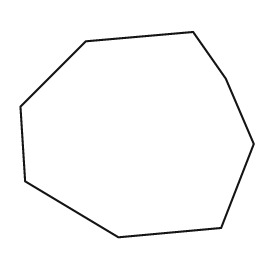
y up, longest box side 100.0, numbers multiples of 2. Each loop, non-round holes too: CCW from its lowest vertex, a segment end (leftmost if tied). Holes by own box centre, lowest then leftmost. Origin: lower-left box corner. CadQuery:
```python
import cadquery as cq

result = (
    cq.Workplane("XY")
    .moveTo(42.0, 0.0)
    .lineTo(86.0, 4.0)
    .lineTo(100.0, 40.0)
    .lineTo(88.0, 68.0)
    .lineTo(74.0, 88.0)
    .lineTo(28.0, 84.0)
    .lineTo(0.0, 56.0)
    .lineTo(2.0, 24.0)
    .close()
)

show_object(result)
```